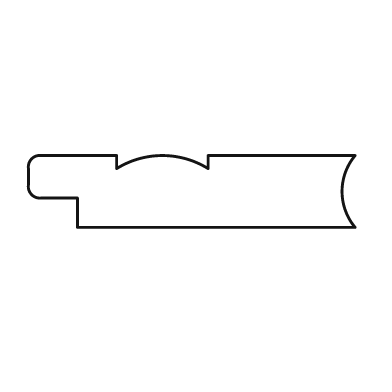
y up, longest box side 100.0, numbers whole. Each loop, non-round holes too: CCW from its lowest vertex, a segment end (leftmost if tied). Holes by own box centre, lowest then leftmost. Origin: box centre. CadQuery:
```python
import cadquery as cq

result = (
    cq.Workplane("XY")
    .moveTo(-35.0, -11.0)
    .lineTo(50.0, -11.0)
    .threePointArc((46.0, 0.0), (50.0, 11.0))
    .lineTo(5.0, 11.0)
    .lineTo(5.0, 7.0)
    .threePointArc((-9.0, 11.0), (-23.0, 7.0))
    .lineTo(-23.0, 11.0)
    .lineTo(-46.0, 11.0)
    .threePointArc((-49.0, 10.0), (-50.0, 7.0))
    .lineTo(-50.0, 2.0)
    .threePointArc((-49.0, -1.0), (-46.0, -2.0))
    .lineTo(-35.0, -2.0)
    .close()
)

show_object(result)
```